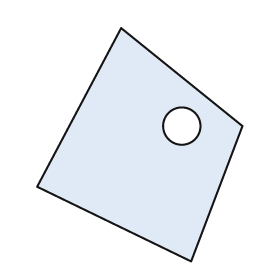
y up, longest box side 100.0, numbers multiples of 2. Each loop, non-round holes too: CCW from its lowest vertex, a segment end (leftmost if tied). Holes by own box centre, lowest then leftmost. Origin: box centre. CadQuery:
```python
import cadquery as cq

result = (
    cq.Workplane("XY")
    .moveTo(22.0, -50.0)
    .lineTo(44.0, 8.0)
    .lineTo(-8.0, 50.0)
    .lineTo(-44.0, -18.0)
    .close()
    .moveTo(18.0, 8.0)
    .circle(8.0)
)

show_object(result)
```